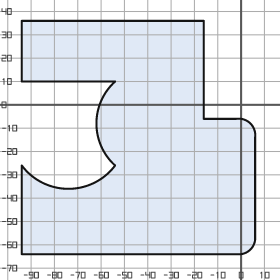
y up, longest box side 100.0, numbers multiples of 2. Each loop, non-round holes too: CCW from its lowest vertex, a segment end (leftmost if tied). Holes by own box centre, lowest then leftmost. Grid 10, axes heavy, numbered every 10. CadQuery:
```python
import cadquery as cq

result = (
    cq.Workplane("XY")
    .moveTo(-94.0, -64.0)
    .lineTo(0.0, -64.0)
    .threePointArc((4.0, -62.0), (6.0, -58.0))
    .lineTo(6.0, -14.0)
    .threePointArc((4.0, -8.0), (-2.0, -6.0))
    .lineTo(-16.0, -6.0)
    .lineTo(-16.0, 36.0)
    .lineTo(-94.0, 36.0)
    .lineTo(-94.0, 10.0)
    .lineTo(-54.0, 10.0)
    .threePointArc((-62.0, -8.0), (-54.0, -26.0))
    .threePointArc((-74.0, -36.0), (-94.0, -26.0))
    .close()
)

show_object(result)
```